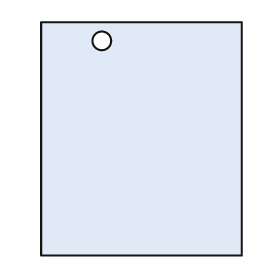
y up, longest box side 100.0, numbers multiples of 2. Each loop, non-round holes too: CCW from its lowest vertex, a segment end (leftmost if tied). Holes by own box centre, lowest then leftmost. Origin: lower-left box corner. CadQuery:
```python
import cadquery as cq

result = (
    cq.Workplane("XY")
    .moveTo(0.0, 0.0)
    .lineTo(86.0, 0.0)
    .lineTo(86.0, 100.0)
    .lineTo(0.0, 100.0)
    .close()
    .moveTo(26.0, 92.0)
    .circle(4.0)
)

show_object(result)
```